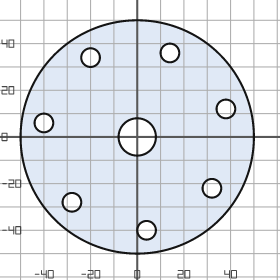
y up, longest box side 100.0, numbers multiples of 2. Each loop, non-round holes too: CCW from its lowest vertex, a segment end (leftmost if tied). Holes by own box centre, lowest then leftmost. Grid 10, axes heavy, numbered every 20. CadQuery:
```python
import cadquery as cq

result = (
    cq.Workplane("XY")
    .moveTo(0.0, 0.0)
    .circle(50.0)
    .moveTo(4.0, -40.0)
    .circle(4.0)
    .moveTo(-28.0, -28.0)
    .circle(4.0)
    .moveTo(32.0, -22.0)
    .circle(4.0)
    .moveTo(0.0, 0.0)
    .circle(8.0)
    .moveTo(-40.0, 6.0)
    .circle(4.0)
    .moveTo(38.0, 12.0)
    .circle(4.0)
    .moveTo(-20.0, 34.0)
    .circle(4.0)
    .moveTo(14.0, 36.0)
    .circle(4.0)
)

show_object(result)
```